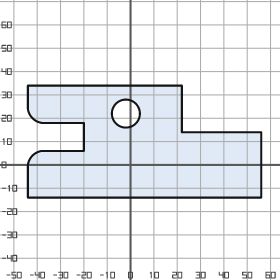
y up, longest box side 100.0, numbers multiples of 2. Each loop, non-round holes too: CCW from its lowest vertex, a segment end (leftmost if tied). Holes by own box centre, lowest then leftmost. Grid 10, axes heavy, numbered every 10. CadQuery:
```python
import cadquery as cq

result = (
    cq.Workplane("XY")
    .moveTo(-44.0, -14.0)
    .lineTo(56.0, -14.0)
    .lineTo(56.0, 14.0)
    .lineTo(22.0, 14.0)
    .lineTo(22.0, 34.0)
    .lineTo(-44.0, 34.0)
    .lineTo(-44.0, 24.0)
    .threePointArc((-42.0, 20.0), (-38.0, 18.0))
    .lineTo(-20.0, 18.0)
    .lineTo(-20.0, 6.0)
    .lineTo(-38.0, 6.0)
    .threePointArc((-42.0, 4.0), (-44.0, 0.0))
    .close()
    .moveTo(-2.0, 22.0)
    .circle(6.0)
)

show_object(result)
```